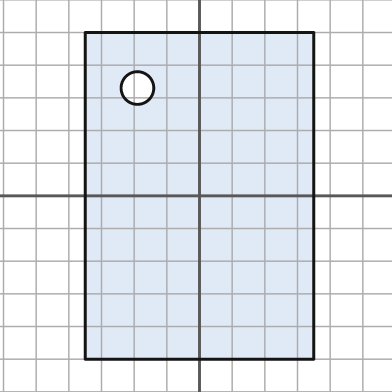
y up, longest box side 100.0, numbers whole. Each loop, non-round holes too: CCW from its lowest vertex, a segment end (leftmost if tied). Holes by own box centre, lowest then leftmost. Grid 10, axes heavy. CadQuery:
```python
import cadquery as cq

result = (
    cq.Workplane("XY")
    .moveTo(-35.0, -50.0)
    .lineTo(35.0, -50.0)
    .lineTo(35.0, 50.0)
    .lineTo(-35.0, 50.0)
    .close()
    .moveTo(-19.0, 33.0)
    .circle(5.0)
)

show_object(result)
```